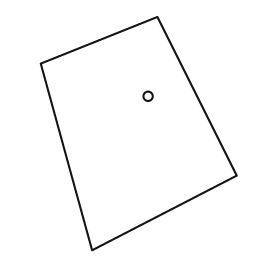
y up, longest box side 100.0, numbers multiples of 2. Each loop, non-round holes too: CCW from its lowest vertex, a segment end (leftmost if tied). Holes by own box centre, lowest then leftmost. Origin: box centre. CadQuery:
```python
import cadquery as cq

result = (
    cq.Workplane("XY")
    .moveTo(-20.0, -50.0)
    .lineTo(42.0, -18.0)
    .lineTo(8.0, 50.0)
    .lineTo(-42.0, 30.0)
    .close()
    .moveTo(4.0, 16.0)
    .circle(2.0)
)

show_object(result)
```